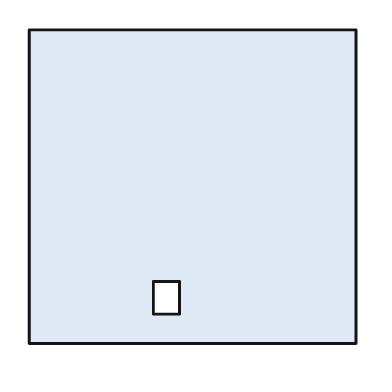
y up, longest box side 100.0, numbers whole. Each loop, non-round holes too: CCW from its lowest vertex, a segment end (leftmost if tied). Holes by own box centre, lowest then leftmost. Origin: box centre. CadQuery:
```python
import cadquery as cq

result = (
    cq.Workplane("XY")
    .moveTo(-50.0, -48.0)
    .lineTo(50.0, -48.0)
    .lineTo(50.0, 48.0)
    .lineTo(-50.0, 48.0)
    .close()
    .moveTo(-12.0, -39.0)
    .lineTo(-4.0, -39.0)
    .lineTo(-4.0, -29.0)
    .lineTo(-12.0, -29.0)
    .close()
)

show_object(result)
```